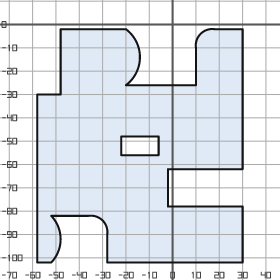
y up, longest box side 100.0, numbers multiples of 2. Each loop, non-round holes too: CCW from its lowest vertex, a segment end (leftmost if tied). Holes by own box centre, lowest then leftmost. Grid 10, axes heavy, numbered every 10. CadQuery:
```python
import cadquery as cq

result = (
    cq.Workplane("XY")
    .moveTo(-58.0, -102.0)
    .lineTo(-52.0, -102.0)
    .threePointArc((-48.0, -92.0), (-52.0, -82.0))
    .lineTo(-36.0, -82.0)
    .threePointArc((-30.0, -84.0), (-28.0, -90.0))
    .lineTo(-28.0, -102.0)
    .lineTo(30.0, -102.0)
    .lineTo(30.0, -78.0)
    .lineTo(-2.0, -78.0)
    .lineTo(-2.0, -62.0)
    .lineTo(30.0, -62.0)
    .lineTo(30.0, -2.0)
    .lineTo(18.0, -2.0)
    .threePointArc((12.0, -4.0), (10.0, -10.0))
    .lineTo(10.0, -26.0)
    .lineTo(-20.0, -26.0)
    .threePointArc((-14.0, -14.0), (-20.0, -2.0))
    .lineTo(-48.0, -2.0)
    .lineTo(-48.0, -30.0)
    .lineTo(-58.0, -30.0)
    .close()
    .moveTo(-22.0, -56.0)
    .lineTo(-6.0, -56.0)
    .lineTo(-6.0, -48.0)
    .lineTo(-22.0, -48.0)
    .close()
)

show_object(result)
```